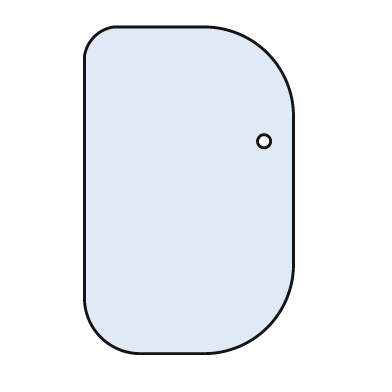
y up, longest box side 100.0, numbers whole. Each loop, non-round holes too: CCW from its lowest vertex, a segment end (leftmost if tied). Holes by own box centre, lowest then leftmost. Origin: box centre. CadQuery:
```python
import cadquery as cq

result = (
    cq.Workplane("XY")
    .moveTo(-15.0, -50.0)
    .lineTo(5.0, -50.0)
    .threePointArc((24.0, -42.0), (32.0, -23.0))
    .lineTo(32.0, 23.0)
    .threePointArc((24.0, 42.0), (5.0, 50.0))
    .lineTo(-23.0, 50.0)
    .threePointArc((-29.0, 47.0), (-32.0, 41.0))
    .lineTo(-32.0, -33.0)
    .threePointArc((-27.0, -45.0), (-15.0, -50.0))
    .close()
    .moveTo(23.0, 15.0)
    .circle(2.0)
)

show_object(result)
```